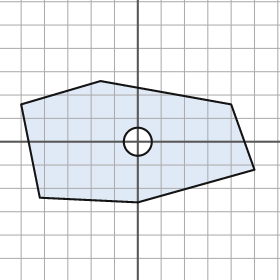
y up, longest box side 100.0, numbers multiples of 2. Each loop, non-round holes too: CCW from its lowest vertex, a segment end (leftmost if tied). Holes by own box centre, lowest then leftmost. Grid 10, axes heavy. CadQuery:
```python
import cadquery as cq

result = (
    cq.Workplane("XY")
    .moveTo(0.0, -26.0)
    .lineTo(50.0, -12.0)
    .lineTo(40.0, 16.0)
    .lineTo(-16.0, 26.0)
    .lineTo(-50.0, 16.0)
    .lineTo(-42.0, -24.0)
    .close()
    .moveTo(0.0, 0.0)
    .circle(6.0)
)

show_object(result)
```